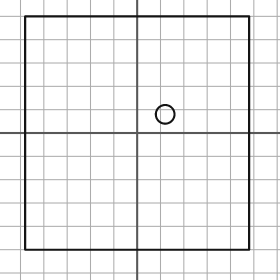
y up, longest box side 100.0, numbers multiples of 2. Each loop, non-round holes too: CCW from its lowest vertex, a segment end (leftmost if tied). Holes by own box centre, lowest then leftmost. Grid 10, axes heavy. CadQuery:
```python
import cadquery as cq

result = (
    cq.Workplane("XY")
    .moveTo(-48.0, -50.0)
    .lineTo(48.0, -50.0)
    .lineTo(48.0, 50.0)
    .lineTo(-48.0, 50.0)
    .close()
    .moveTo(12.0, 8.0)
    .circle(4.0)
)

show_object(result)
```